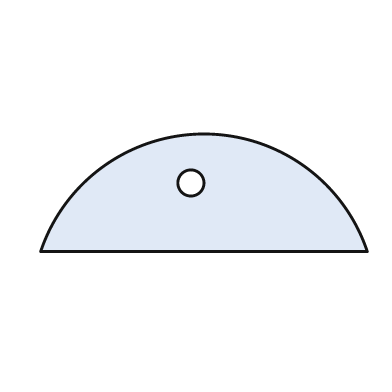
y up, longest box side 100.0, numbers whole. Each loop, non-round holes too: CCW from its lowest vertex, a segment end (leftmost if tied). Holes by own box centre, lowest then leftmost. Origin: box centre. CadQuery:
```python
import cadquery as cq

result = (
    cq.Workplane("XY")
    .moveTo(-50.0, -18.0)
    .lineTo(50.0, -18.0)
    .threePointArc((0.0, 18.0), (-50.0, -18.0))
    .close()
    .moveTo(-4.0, 3.0)
    .circle(4.0)
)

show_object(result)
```